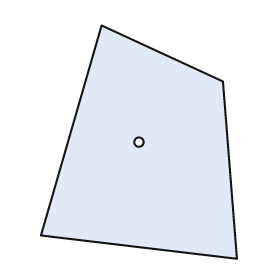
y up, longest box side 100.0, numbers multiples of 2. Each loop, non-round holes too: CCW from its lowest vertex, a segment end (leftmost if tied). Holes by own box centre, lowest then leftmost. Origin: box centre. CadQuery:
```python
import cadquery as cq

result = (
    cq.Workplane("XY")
    .moveTo(42.0, -50.0)
    .lineTo(36.0, 26.0)
    .lineTo(-16.0, 50.0)
    .lineTo(-42.0, -40.0)
    .close()
    .moveTo(0.0, 0.0)
    .circle(2.0)
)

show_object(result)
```